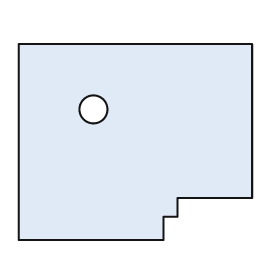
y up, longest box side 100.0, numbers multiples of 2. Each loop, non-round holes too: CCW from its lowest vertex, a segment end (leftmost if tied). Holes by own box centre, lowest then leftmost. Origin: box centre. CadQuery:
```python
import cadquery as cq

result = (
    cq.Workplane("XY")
    .moveTo(-50.0, -42.0)
    .lineTo(12.0, -42.0)
    .lineTo(12.0, -32.0)
    .lineTo(18.0, -32.0)
    .lineTo(18.0, -24.0)
    .lineTo(50.0, -24.0)
    .lineTo(50.0, 42.0)
    .lineTo(-50.0, 42.0)
    .close()
    .moveTo(-18.0, 14.0)
    .circle(6.0)
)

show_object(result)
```